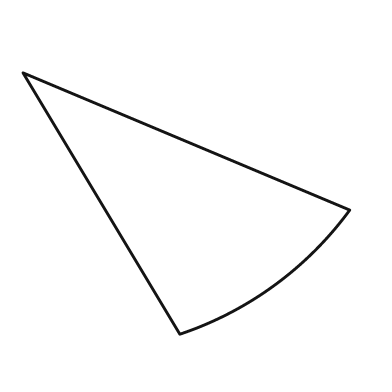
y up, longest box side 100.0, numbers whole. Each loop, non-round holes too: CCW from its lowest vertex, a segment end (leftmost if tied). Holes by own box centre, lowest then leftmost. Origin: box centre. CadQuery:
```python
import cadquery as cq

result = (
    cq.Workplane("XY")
    .moveTo(-2.0, -40.0)
    .threePointArc((27.0, -25.0), (50.0, -2.0))
    .lineTo(-50.0, 40.0)
    .close()
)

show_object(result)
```